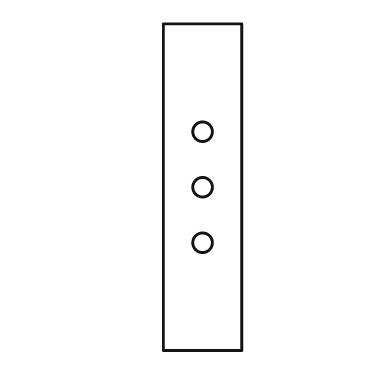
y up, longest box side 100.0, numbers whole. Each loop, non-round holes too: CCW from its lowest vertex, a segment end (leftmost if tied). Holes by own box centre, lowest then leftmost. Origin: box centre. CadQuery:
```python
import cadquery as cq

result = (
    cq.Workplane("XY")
    .moveTo(-12.0, -50.0)
    .lineTo(12.0, -50.0)
    .lineTo(12.0, 50.0)
    .lineTo(-12.0, 50.0)
    .close()
    .moveTo(0.0, -17.0)
    .circle(3.0)
    .moveTo(0.0, 0.0)
    .circle(3.0)
    .moveTo(0.0, 17.0)
    .circle(3.0)
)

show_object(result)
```